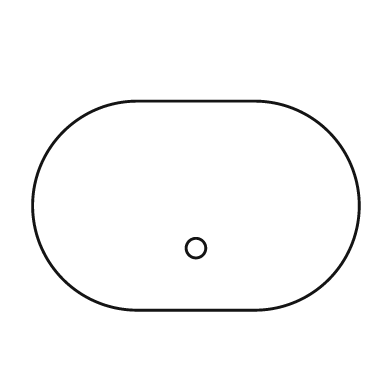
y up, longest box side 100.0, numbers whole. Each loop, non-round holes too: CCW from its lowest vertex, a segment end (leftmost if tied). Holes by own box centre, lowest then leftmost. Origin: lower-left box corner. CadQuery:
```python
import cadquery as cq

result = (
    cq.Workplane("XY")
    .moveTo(32.0, 0.0)
    .lineTo(68.0, 0.0)
    .threePointArc((100.0, 32.0), (68.0, 64.0))
    .lineTo(32.0, 64.0)
    .threePointArc((0.0, 32.0), (32.0, 0.0))
    .close()
    .moveTo(50.0, 19.0)
    .circle(3.0)
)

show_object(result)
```